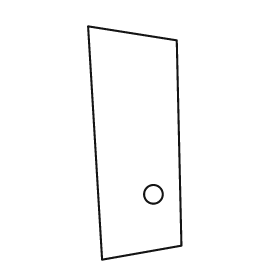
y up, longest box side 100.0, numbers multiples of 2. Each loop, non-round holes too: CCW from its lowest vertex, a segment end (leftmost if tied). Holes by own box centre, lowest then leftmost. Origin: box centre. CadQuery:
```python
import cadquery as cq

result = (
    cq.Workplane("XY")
    .moveTo(-14.0, -50.0)
    .lineTo(20.0, -44.0)
    .lineTo(18.0, 44.0)
    .lineTo(-20.0, 50.0)
    .close()
    .moveTo(8.0, -22.0)
    .circle(4.0)
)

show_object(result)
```